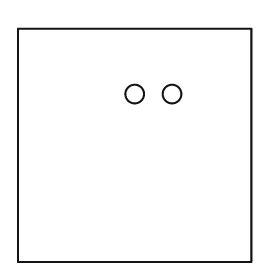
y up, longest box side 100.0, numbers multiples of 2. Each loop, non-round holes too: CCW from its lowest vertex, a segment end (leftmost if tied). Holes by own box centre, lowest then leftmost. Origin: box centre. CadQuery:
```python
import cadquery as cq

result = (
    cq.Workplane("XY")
    .moveTo(-50.0, -50.0)
    .lineTo(50.0, -50.0)
    .lineTo(50.0, 50.0)
    .lineTo(-50.0, 50.0)
    .close()
    .moveTo(0.0, 22.0)
    .circle(4.0)
    .moveTo(16.0, 22.0)
    .circle(4.0)
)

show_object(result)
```